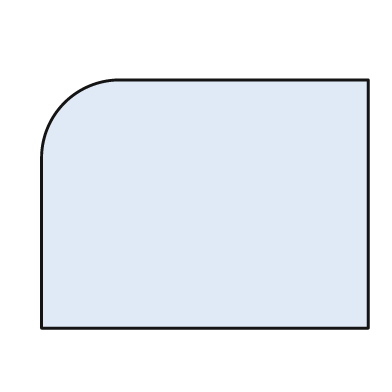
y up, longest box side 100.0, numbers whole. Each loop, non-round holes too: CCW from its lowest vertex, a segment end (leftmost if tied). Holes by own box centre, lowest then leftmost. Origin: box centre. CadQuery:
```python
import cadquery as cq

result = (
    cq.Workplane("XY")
    .moveTo(-50.0, -38.0)
    .lineTo(50.0, -38.0)
    .lineTo(50.0, 38.0)
    .lineTo(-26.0, 38.0)
    .threePointArc((-43.0, 31.0), (-50.0, 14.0))
    .close()
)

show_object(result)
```